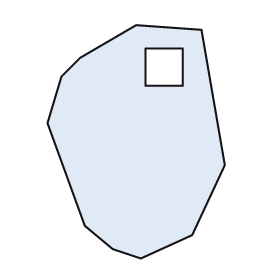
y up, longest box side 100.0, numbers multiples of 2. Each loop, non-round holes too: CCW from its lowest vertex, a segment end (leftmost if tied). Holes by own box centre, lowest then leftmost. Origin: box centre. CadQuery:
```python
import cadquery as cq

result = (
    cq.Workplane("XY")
    .moveTo(2.0, -50.0)
    .lineTo(24.0, -40.0)
    .lineTo(38.0, -10.0)
    .lineTo(28.0, 48.0)
    .lineTo(0.0, 50.0)
    .lineTo(-24.0, 36.0)
    .lineTo(-32.0, 28.0)
    .lineTo(-38.0, 8.0)
    .lineTo(-22.0, -36.0)
    .lineTo(-10.0, -46.0)
    .close()
    .moveTo(4.0, 24.0)
    .lineTo(20.0, 24.0)
    .lineTo(20.0, 40.0)
    .lineTo(4.0, 40.0)
    .close()
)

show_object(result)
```